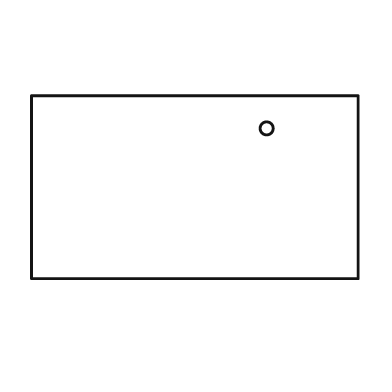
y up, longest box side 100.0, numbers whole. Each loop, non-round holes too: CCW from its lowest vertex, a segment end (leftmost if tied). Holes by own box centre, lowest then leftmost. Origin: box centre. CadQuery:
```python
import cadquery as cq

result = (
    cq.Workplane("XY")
    .moveTo(-50.0, -28.0)
    .lineTo(50.0, -28.0)
    .lineTo(50.0, 28.0)
    .lineTo(-50.0, 28.0)
    .close()
    .moveTo(22.0, 18.0)
    .circle(2.0)
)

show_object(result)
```